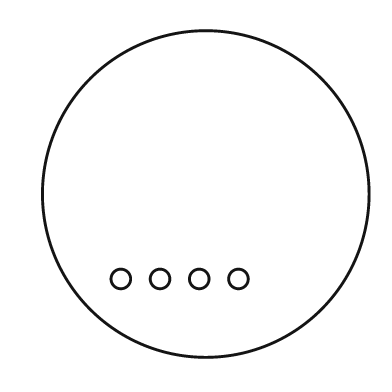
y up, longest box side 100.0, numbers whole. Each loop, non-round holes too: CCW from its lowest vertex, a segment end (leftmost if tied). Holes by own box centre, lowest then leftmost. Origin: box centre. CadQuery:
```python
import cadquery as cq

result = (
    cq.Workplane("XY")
    .moveTo(0.0, 0.0)
    .circle(50.0)
    .moveTo(-26.0, -26.0)
    .circle(3.0)
    .moveTo(-14.0, -26.0)
    .circle(3.0)
    .moveTo(-2.0, -26.0)
    .circle(3.0)
    .moveTo(10.0, -26.0)
    .circle(3.0)
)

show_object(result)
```